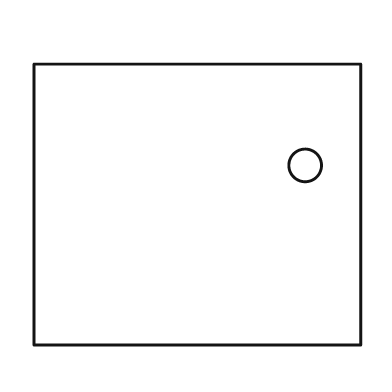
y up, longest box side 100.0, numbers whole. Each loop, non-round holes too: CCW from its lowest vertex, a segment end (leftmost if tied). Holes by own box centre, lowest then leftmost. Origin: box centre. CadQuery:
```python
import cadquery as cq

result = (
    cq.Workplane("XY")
    .moveTo(-50.0, -43.0)
    .lineTo(50.0, -43.0)
    .lineTo(50.0, 43.0)
    .lineTo(-50.0, 43.0)
    .close()
    .moveTo(33.0, 12.0)
    .circle(5.0)
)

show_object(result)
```